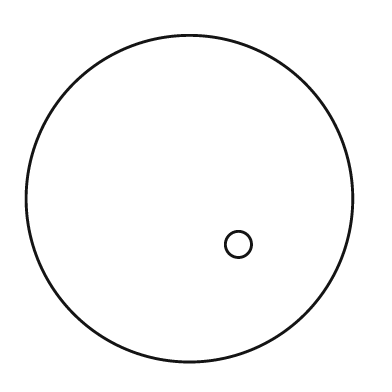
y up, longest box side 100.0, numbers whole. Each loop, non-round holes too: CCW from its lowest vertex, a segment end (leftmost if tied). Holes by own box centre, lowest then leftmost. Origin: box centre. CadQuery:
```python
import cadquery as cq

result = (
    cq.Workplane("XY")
    .moveTo(0.0, 0.0)
    .circle(50.0)
    .moveTo(15.0, -14.0)
    .circle(4.0)
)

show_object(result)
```